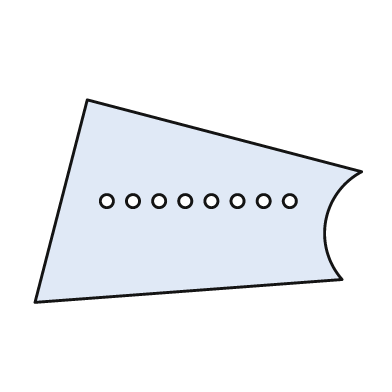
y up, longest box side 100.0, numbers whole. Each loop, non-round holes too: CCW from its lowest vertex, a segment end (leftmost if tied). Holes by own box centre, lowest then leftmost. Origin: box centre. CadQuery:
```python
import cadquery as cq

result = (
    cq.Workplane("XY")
    .moveTo(-50.0, -31.0)
    .lineTo(44.0, -24.0)
    .threePointArc((39.0, -6.0), (50.0, 9.0))
    .lineTo(-34.0, 31.0)
    .close()
    .moveTo(-28.0, 0.0)
    .circle(2.0)
    .moveTo(-20.0, 0.0)
    .circle(2.0)
    .moveTo(-12.0, 0.0)
    .circle(2.0)
    .moveTo(-4.0, 0.0)
    .circle(2.0)
    .moveTo(4.0, 0.0)
    .circle(2.0)
    .moveTo(12.0, 0.0)
    .circle(2.0)
    .moveTo(20.0, 0.0)
    .circle(2.0)
    .moveTo(28.0, 0.0)
    .circle(2.0)
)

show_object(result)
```